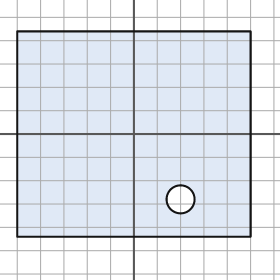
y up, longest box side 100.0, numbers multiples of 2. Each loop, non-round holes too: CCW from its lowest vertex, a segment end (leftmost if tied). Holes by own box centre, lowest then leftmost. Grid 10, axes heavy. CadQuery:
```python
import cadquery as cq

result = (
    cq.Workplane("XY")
    .moveTo(-50.0, -44.0)
    .lineTo(50.0, -44.0)
    .lineTo(50.0, 44.0)
    .lineTo(-50.0, 44.0)
    .close()
    .moveTo(20.0, -28.0)
    .circle(6.0)
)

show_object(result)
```